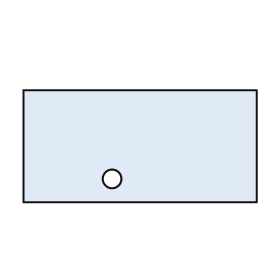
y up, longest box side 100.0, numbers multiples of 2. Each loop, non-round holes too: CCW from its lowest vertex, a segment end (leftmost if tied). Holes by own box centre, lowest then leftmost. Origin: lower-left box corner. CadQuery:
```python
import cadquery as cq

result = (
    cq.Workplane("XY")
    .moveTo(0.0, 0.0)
    .lineTo(100.0, 0.0)
    .lineTo(100.0, 48.0)
    .lineTo(0.0, 48.0)
    .close()
    .moveTo(38.0, 10.0)
    .circle(4.0)
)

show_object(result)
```